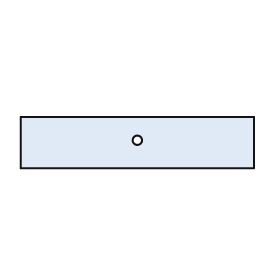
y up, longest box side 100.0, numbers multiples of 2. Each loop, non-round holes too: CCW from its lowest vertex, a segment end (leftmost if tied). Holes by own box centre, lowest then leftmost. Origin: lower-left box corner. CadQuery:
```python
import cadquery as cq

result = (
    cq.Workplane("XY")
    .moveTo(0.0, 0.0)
    .lineTo(100.0, 0.0)
    .lineTo(100.0, 22.0)
    .lineTo(0.0, 22.0)
    .close()
    .moveTo(50.0, 12.0)
    .circle(2.0)
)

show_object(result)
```